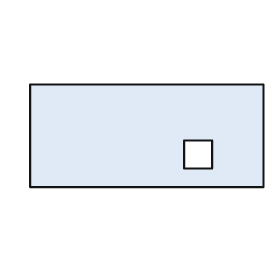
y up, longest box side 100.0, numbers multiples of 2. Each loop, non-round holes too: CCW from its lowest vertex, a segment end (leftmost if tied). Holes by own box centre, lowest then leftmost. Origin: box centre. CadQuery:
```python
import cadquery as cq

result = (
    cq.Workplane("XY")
    .moveTo(-50.0, -22.0)
    .lineTo(50.0, -22.0)
    .lineTo(50.0, 22.0)
    .lineTo(-50.0, 22.0)
    .close()
    .moveTo(16.0, -14.0)
    .lineTo(28.0, -14.0)
    .lineTo(28.0, -2.0)
    .lineTo(16.0, -2.0)
    .close()
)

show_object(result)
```